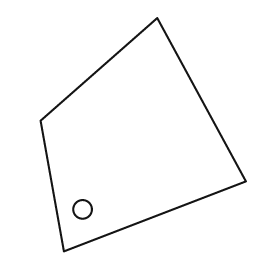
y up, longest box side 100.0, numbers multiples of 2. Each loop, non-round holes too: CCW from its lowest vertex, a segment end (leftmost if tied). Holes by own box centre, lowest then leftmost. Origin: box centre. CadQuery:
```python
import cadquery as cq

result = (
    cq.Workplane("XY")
    .moveTo(-34.0, -50.0)
    .lineTo(44.0, -20.0)
    .lineTo(6.0, 50.0)
    .lineTo(-44.0, 6.0)
    .close()
    .moveTo(-26.0, -32.0)
    .circle(4.0)
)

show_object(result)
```